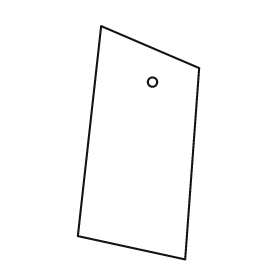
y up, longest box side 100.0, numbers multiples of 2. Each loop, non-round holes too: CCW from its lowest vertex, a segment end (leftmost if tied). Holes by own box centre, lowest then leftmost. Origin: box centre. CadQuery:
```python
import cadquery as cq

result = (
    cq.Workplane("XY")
    .moveTo(20.0, -50.0)
    .lineTo(26.0, 32.0)
    .lineTo(-16.0, 50.0)
    .lineTo(-26.0, -40.0)
    .close()
    .moveTo(6.0, 26.0)
    .circle(2.0)
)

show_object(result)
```